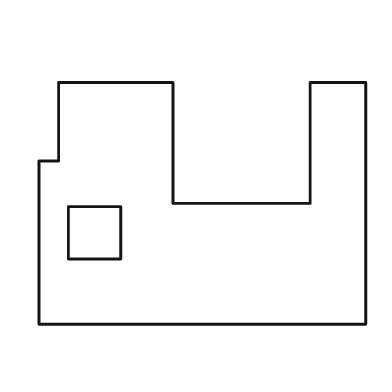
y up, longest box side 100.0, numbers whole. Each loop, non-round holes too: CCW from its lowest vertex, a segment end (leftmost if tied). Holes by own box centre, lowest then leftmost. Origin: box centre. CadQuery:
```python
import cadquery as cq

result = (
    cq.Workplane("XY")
    .moveTo(-50.0, -37.0)
    .lineTo(50.0, -37.0)
    .lineTo(50.0, 37.0)
    .lineTo(33.0, 37.0)
    .lineTo(33.0, 0.0)
    .lineTo(-9.0, 0.0)
    .lineTo(-9.0, 37.0)
    .lineTo(-44.0, 37.0)
    .lineTo(-44.0, 13.0)
    .lineTo(-50.0, 13.0)
    .close()
    .moveTo(-41.0, -17.0)
    .lineTo(-25.0, -17.0)
    .lineTo(-25.0, -1.0)
    .lineTo(-41.0, -1.0)
    .close()
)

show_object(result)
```